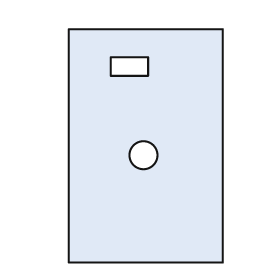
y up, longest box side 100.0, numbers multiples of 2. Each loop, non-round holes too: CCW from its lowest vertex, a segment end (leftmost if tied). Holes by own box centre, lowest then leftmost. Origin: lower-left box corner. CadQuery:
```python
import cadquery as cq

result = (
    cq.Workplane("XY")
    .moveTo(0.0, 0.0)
    .lineTo(66.0, 0.0)
    .lineTo(66.0, 100.0)
    .lineTo(0.0, 100.0)
    .close()
    .moveTo(32.0, 46.0)
    .circle(6.0)
    .moveTo(18.0, 80.0)
    .lineTo(34.0, 80.0)
    .lineTo(34.0, 88.0)
    .lineTo(18.0, 88.0)
    .close()
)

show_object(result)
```